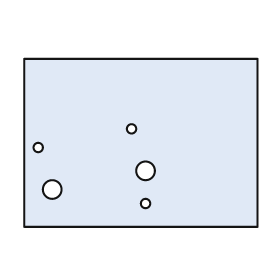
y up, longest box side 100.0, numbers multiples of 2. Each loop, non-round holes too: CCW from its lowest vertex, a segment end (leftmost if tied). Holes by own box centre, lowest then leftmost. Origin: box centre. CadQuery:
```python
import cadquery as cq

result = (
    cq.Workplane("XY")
    .moveTo(-50.0, -36.0)
    .lineTo(50.0, -36.0)
    .lineTo(50.0, 36.0)
    .lineTo(-50.0, 36.0)
    .close()
    .moveTo(2.0, -26.0)
    .circle(2.0)
    .moveTo(-38.0, -20.0)
    .circle(4.0)
    .moveTo(2.0, -12.0)
    .circle(4.0)
    .moveTo(-44.0, -2.0)
    .circle(2.0)
    .moveTo(-4.0, 6.0)
    .circle(2.0)
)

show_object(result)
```